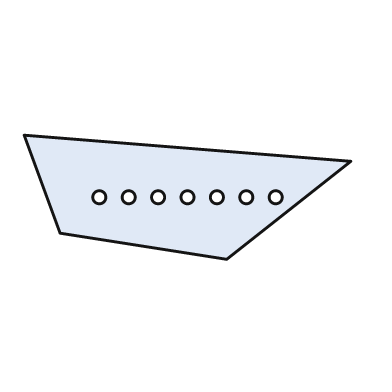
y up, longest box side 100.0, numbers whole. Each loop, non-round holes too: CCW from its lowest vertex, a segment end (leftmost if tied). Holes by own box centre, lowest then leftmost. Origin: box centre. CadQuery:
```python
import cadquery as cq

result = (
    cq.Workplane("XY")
    .moveTo(12.0, -19.0)
    .lineTo(50.0, 11.0)
    .lineTo(-50.0, 19.0)
    .lineTo(-39.0, -11.0)
    .close()
    .moveTo(-27.0, 0.0)
    .circle(2.0)
    .moveTo(-18.0, 0.0)
    .circle(2.0)
    .moveTo(-9.0, 0.0)
    .circle(2.0)
    .moveTo(0.0, 0.0)
    .circle(2.0)
    .moveTo(9.0, 0.0)
    .circle(2.0)
    .moveTo(18.0, 0.0)
    .circle(2.0)
    .moveTo(27.0, 0.0)
    .circle(2.0)
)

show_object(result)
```